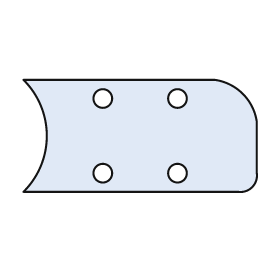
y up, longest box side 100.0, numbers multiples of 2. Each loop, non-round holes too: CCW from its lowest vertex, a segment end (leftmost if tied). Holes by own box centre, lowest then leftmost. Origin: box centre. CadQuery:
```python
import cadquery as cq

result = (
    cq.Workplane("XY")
    .moveTo(-50.0, -24.0)
    .lineTo(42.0, -24.0)
    .threePointArc((48.0, -22.0), (50.0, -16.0))
    .lineTo(50.0, 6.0)
    .threePointArc((44.0, 18.0), (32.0, 24.0))
    .lineTo(-50.0, 24.0)
    .threePointArc((-40.0, 0.0), (-50.0, -24.0))
    .close()
    .moveTo(-16.0, -16.0)
    .circle(4.0)
    .moveTo(16.0, -16.0)
    .circle(4.0)
    .moveTo(-16.0, 16.0)
    .circle(4.0)
    .moveTo(16.0, 16.0)
    .circle(4.0)
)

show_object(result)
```